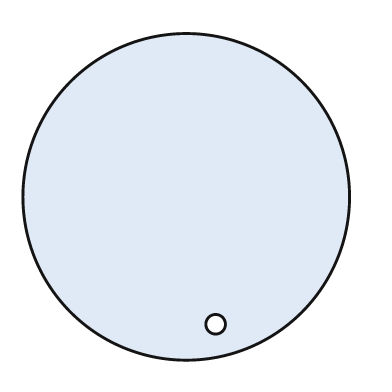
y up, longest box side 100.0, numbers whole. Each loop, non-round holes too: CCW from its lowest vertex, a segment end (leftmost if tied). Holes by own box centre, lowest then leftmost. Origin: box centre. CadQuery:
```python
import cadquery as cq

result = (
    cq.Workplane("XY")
    .moveTo(0.0, 0.0)
    .circle(50.0)
    .moveTo(9.0, -39.0)
    .circle(3.0)
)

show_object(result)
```